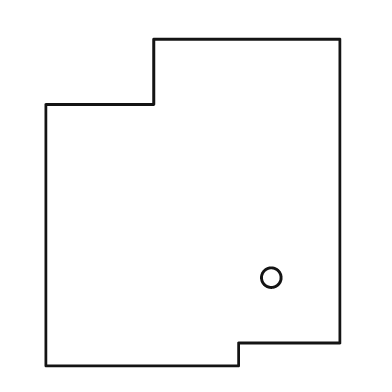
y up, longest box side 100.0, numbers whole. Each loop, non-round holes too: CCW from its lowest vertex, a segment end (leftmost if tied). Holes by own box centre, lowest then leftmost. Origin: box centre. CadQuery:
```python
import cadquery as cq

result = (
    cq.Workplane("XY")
    .moveTo(-45.0, -50.0)
    .lineTo(14.0, -50.0)
    .lineTo(14.0, -43.0)
    .lineTo(45.0, -43.0)
    .lineTo(45.0, 50.0)
    .lineTo(-12.0, 50.0)
    .lineTo(-12.0, 30.0)
    .lineTo(-45.0, 30.0)
    .close()
    .moveTo(24.0, -23.0)
    .circle(3.0)
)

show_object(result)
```